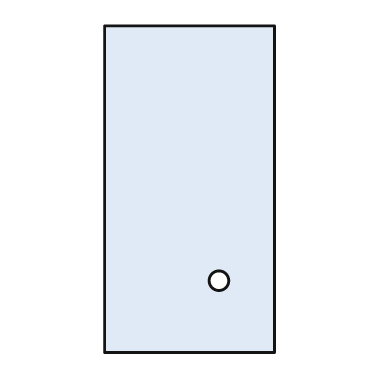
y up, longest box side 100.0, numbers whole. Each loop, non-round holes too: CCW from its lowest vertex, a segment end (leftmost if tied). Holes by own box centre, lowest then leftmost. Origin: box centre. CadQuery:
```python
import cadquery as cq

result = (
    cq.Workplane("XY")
    .moveTo(-26.0, -50.0)
    .lineTo(26.0, -50.0)
    .lineTo(26.0, 50.0)
    .lineTo(-26.0, 50.0)
    .close()
    .moveTo(9.0, -28.0)
    .circle(3.0)
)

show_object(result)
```